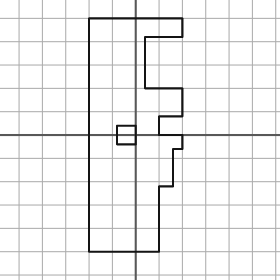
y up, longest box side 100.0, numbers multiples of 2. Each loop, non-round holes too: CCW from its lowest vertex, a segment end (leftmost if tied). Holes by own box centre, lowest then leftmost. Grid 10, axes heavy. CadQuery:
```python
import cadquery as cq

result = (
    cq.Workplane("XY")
    .moveTo(-20.0, -50.0)
    .lineTo(10.0, -50.0)
    .lineTo(10.0, -22.0)
    .lineTo(16.0, -22.0)
    .lineTo(16.0, -6.0)
    .lineTo(20.0, -6.0)
    .lineTo(20.0, 0.0)
    .lineTo(10.0, 0.0)
    .lineTo(10.0, 8.0)
    .lineTo(20.0, 8.0)
    .lineTo(20.0, 20.0)
    .lineTo(4.0, 20.0)
    .lineTo(4.0, 42.0)
    .lineTo(20.0, 42.0)
    .lineTo(20.0, 50.0)
    .lineTo(-20.0, 50.0)
    .close()
    .moveTo(-8.0, -4.0)
    .lineTo(0.0, -4.0)
    .lineTo(0.0, 4.0)
    .lineTo(-8.0, 4.0)
    .close()
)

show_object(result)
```